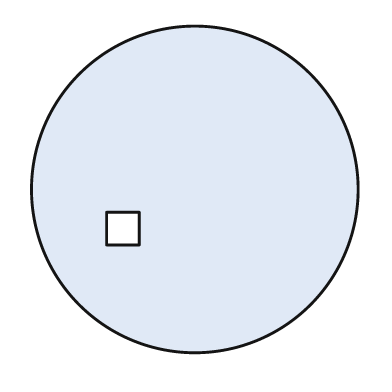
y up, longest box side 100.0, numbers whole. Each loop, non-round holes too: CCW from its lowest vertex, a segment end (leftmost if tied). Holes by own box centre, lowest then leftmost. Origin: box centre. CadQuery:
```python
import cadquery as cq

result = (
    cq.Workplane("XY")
    .moveTo(0.0, 0.0)
    .circle(50.0)
    .moveTo(-27.0, -17.0)
    .lineTo(-17.0, -17.0)
    .lineTo(-17.0, -7.0)
    .lineTo(-27.0, -7.0)
    .close()
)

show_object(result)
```